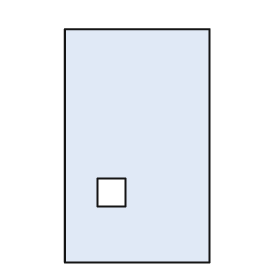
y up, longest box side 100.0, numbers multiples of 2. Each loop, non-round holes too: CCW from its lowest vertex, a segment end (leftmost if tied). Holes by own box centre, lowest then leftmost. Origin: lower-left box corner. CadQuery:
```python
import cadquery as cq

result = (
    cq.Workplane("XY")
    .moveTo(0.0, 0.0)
    .lineTo(62.0, 0.0)
    .lineTo(62.0, 100.0)
    .lineTo(0.0, 100.0)
    .close()
    .moveTo(14.0, 24.0)
    .lineTo(26.0, 24.0)
    .lineTo(26.0, 36.0)
    .lineTo(14.0, 36.0)
    .close()
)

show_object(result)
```